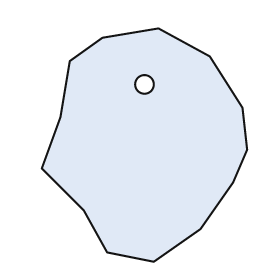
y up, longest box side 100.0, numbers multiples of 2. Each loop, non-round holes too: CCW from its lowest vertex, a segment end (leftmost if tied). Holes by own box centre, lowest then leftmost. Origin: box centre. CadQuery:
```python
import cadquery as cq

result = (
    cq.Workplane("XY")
    .moveTo(4.0, -50.0)
    .lineTo(24.0, -36.0)
    .lineTo(38.0, -16.0)
    .lineTo(44.0, -2.0)
    .lineTo(42.0, 16.0)
    .lineTo(28.0, 38.0)
    .lineTo(6.0, 50.0)
    .lineTo(-18.0, 46.0)
    .lineTo(-32.0, 36.0)
    .lineTo(-36.0, 12.0)
    .lineTo(-44.0, -10.0)
    .lineTo(-26.0, -28.0)
    .lineTo(-16.0, -46.0)
    .close()
    .moveTo(0.0, 26.0)
    .circle(4.0)
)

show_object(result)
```